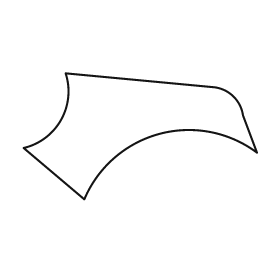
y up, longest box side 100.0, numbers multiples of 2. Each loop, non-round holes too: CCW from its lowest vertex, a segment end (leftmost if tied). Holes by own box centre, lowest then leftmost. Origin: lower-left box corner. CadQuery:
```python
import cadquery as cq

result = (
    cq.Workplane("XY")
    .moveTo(26.0, 0.0)
    .threePointArc((58.0, 28.0), (100.0, 20.0))
    .lineTo(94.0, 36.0)
    .threePointArc((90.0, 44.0), (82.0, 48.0))
    .lineTo(18.0, 54.0)
    .threePointArc((16.0, 34.0), (0.0, 22.0))
    .close()
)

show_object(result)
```